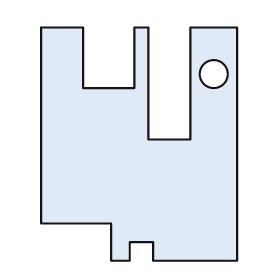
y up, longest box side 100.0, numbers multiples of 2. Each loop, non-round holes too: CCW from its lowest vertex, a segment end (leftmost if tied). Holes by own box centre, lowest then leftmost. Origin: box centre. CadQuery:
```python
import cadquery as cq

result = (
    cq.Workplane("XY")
    .moveTo(-12.0, -50.0)
    .lineTo(-4.0, -50.0)
    .lineTo(-4.0, -42.0)
    .lineTo(6.0, -42.0)
    .lineTo(6.0, -50.0)
    .lineTo(42.0, -50.0)
    .lineTo(42.0, 50.0)
    .lineTo(22.0, 50.0)
    .lineTo(22.0, 2.0)
    .lineTo(4.0, 2.0)
    .lineTo(4.0, 50.0)
    .lineTo(-2.0, 50.0)
    .lineTo(-2.0, 24.0)
    .lineTo(-24.0, 24.0)
    .lineTo(-24.0, 50.0)
    .lineTo(-42.0, 50.0)
    .lineTo(-42.0, -34.0)
    .lineTo(-12.0, -34.0)
    .close()
    .moveTo(32.0, 30.0)
    .circle(6.0)
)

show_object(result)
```